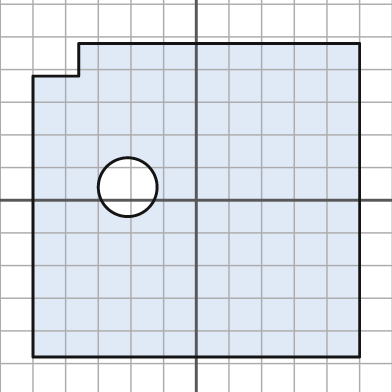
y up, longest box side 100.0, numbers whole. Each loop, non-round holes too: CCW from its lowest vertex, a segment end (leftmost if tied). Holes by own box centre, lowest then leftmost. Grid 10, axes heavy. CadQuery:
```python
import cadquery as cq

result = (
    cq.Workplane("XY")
    .moveTo(-50.0, -48.0)
    .lineTo(50.0, -48.0)
    .lineTo(50.0, 48.0)
    .lineTo(-36.0, 48.0)
    .lineTo(-36.0, 38.0)
    .lineTo(-50.0, 38.0)
    .close()
    .moveTo(-21.0, 4.0)
    .circle(9.0)
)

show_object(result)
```